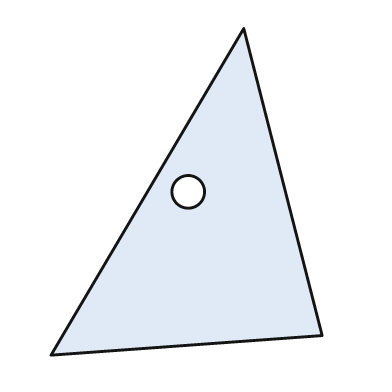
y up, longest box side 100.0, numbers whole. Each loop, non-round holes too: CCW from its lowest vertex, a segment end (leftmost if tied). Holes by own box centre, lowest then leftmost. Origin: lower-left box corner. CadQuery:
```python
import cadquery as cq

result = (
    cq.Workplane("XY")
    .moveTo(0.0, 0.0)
    .lineTo(83.0, 6.0)
    .lineTo(59.0, 100.0)
    .close()
    .moveTo(42.0, 50.0)
    .circle(5.0)
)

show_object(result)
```